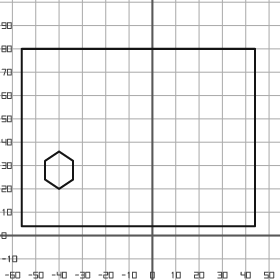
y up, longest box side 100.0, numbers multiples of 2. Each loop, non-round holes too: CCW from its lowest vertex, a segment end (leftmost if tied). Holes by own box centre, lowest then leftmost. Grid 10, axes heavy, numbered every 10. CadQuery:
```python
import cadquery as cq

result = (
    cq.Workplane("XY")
    .moveTo(-56.0, 4.0)
    .lineTo(44.0, 4.0)
    .lineTo(44.0, 80.0)
    .lineTo(-56.0, 80.0)
    .close()
    .moveTo(-40.0, 20.0)
    .lineTo(-34.0, 24.0)
    .lineTo(-34.0, 32.0)
    .lineTo(-40.0, 36.0)
    .lineTo(-46.0, 32.0)
    .lineTo(-46.0, 24.0)
    .close()
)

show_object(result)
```